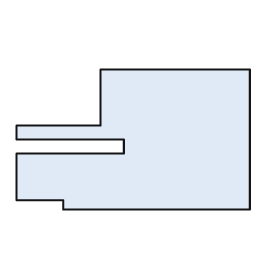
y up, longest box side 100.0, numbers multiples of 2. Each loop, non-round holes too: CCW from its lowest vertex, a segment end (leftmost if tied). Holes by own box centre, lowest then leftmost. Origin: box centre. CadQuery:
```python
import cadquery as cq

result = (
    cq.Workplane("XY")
    .moveTo(-30.0, -30.0)
    .lineTo(50.0, -30.0)
    .lineTo(50.0, 30.0)
    .lineTo(-14.0, 30.0)
    .lineTo(-14.0, 6.0)
    .lineTo(-50.0, 6.0)
    .lineTo(-50.0, 0.0)
    .lineTo(-4.0, 0.0)
    .lineTo(-4.0, -6.0)
    .lineTo(-50.0, -6.0)
    .lineTo(-50.0, -26.0)
    .lineTo(-30.0, -26.0)
    .close()
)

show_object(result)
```